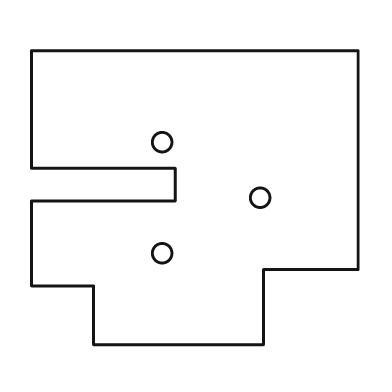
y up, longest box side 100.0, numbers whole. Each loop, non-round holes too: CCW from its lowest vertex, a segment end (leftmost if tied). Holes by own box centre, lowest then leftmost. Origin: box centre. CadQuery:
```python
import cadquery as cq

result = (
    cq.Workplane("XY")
    .moveTo(-31.0, -45.0)
    .lineTo(21.0, -45.0)
    .lineTo(21.0, -22.0)
    .lineTo(50.0, -22.0)
    .lineTo(50.0, 45.0)
    .lineTo(-50.0, 45.0)
    .lineTo(-50.0, 9.0)
    .lineTo(-6.0, 9.0)
    .lineTo(-6.0, -1.0)
    .lineTo(-50.0, -1.0)
    .lineTo(-50.0, -27.0)
    .lineTo(-31.0, -27.0)
    .close()
    .moveTo(-10.0, -17.0)
    .circle(3.0)
    .moveTo(20.0, 0.0)
    .circle(3.0)
    .moveTo(-10.0, 17.0)
    .circle(3.0)
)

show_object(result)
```